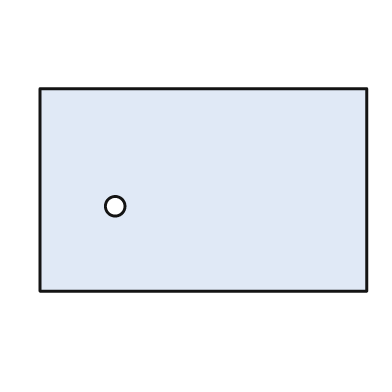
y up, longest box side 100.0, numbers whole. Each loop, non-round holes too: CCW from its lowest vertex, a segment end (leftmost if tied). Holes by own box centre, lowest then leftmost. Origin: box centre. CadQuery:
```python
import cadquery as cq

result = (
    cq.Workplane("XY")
    .moveTo(-50.0, -31.0)
    .lineTo(50.0, -31.0)
    .lineTo(50.0, 31.0)
    .lineTo(-50.0, 31.0)
    .close()
    .moveTo(-27.0, -5.0)
    .circle(3.0)
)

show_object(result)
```